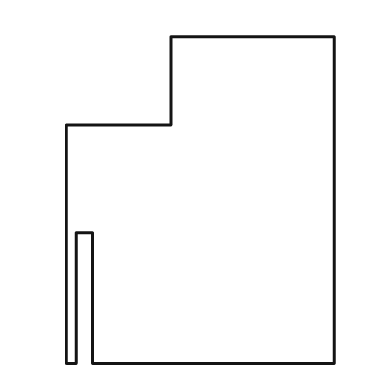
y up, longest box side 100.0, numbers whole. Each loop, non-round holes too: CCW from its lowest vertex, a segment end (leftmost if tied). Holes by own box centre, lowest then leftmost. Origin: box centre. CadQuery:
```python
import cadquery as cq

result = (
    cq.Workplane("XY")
    .moveTo(-41.0, -50.0)
    .lineTo(-38.0, -50.0)
    .lineTo(-38.0, -10.0)
    .lineTo(-33.0, -10.0)
    .lineTo(-33.0, -50.0)
    .lineTo(41.0, -50.0)
    .lineTo(41.0, 50.0)
    .lineTo(-9.0, 50.0)
    .lineTo(-9.0, 23.0)
    .lineTo(-41.0, 23.0)
    .close()
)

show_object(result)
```